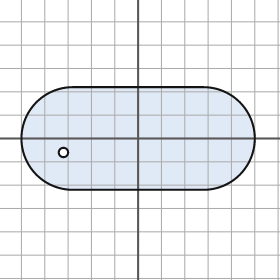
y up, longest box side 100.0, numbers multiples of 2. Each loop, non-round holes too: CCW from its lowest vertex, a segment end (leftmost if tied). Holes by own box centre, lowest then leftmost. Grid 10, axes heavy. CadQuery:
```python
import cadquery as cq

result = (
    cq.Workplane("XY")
    .moveTo(-28.0, -22.0)
    .lineTo(28.0, -22.0)
    .threePointArc((50.0, 0.0), (28.0, 22.0))
    .lineTo(-28.0, 22.0)
    .threePointArc((-50.0, 0.0), (-28.0, -22.0))
    .close()
    .moveTo(-32.0, -6.0)
    .circle(2.0)
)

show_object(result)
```